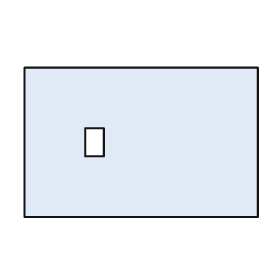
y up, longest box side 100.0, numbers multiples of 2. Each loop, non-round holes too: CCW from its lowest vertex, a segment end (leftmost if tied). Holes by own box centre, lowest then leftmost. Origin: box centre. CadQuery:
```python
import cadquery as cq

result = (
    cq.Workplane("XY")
    .moveTo(-50.0, -32.0)
    .lineTo(50.0, -32.0)
    .lineTo(50.0, 32.0)
    .lineTo(-50.0, 32.0)
    .close()
    .moveTo(-24.0, -6.0)
    .lineTo(-16.0, -6.0)
    .lineTo(-16.0, 6.0)
    .lineTo(-24.0, 6.0)
    .close()
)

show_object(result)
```